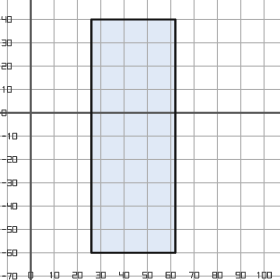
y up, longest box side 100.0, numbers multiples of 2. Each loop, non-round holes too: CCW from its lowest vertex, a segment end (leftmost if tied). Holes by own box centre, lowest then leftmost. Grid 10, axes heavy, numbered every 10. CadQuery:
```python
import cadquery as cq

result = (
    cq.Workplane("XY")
    .moveTo(26.0, -60.0)
    .lineTo(62.0, -60.0)
    .lineTo(62.0, 40.0)
    .lineTo(26.0, 40.0)
    .close()
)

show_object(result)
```